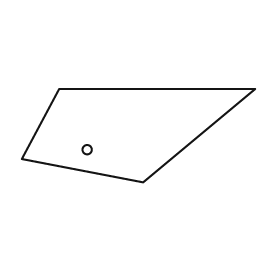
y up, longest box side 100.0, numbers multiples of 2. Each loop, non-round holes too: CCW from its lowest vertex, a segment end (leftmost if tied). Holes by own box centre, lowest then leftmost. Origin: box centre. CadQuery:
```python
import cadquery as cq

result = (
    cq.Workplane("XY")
    .moveTo(2.0, -20.0)
    .lineTo(50.0, 20.0)
    .lineTo(-34.0, 20.0)
    .lineTo(-50.0, -10.0)
    .close()
    .moveTo(-22.0, -6.0)
    .circle(2.0)
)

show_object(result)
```